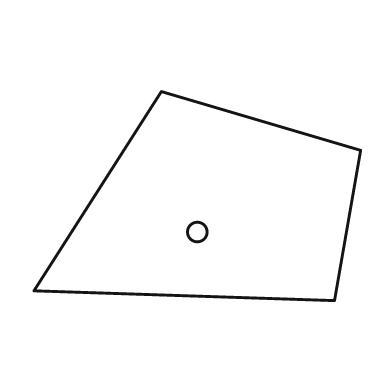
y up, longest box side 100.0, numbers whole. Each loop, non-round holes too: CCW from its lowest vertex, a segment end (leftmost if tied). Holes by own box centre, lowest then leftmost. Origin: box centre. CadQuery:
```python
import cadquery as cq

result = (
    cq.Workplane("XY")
    .moveTo(42.0, -32.0)
    .lineTo(50.0, 14.0)
    .lineTo(-11.0, 32.0)
    .lineTo(-50.0, -29.0)
    .close()
    .moveTo(0.0, -11.0)
    .circle(3.0)
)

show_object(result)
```